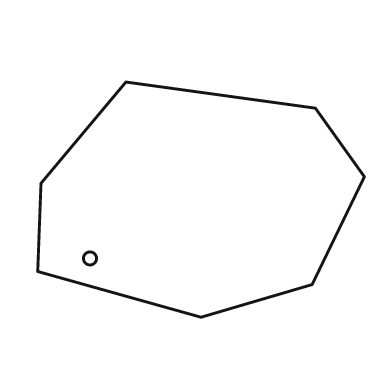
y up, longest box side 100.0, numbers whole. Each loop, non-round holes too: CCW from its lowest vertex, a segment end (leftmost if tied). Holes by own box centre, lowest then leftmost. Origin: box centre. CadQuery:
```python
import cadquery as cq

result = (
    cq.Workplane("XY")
    .moveTo(0.0, -36.0)
    .lineTo(34.0, -26.0)
    .lineTo(50.0, 7.0)
    .lineTo(35.0, 28.0)
    .lineTo(-23.0, 36.0)
    .lineTo(-49.0, 5.0)
    .lineTo(-50.0, -22.0)
    .close()
    .moveTo(-34.0, -18.0)
    .circle(2.0)
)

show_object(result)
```